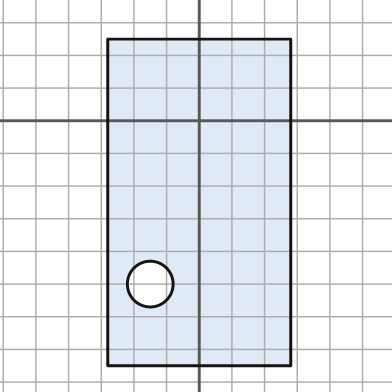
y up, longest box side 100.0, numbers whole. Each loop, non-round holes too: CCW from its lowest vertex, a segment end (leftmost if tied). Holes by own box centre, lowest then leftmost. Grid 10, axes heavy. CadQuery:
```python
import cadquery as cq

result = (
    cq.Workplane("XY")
    .moveTo(-28.0, -75.0)
    .lineTo(28.0, -75.0)
    .lineTo(28.0, 25.0)
    .lineTo(-28.0, 25.0)
    .close()
    .moveTo(-15.0, -50.0)
    .circle(7.0)
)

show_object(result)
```